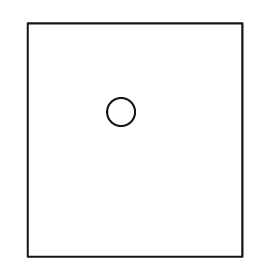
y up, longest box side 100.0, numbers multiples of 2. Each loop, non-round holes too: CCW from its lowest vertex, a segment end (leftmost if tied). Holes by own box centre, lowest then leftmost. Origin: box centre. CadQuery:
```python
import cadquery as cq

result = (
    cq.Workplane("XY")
    .moveTo(-46.0, -50.0)
    .lineTo(46.0, -50.0)
    .lineTo(46.0, 50.0)
    .lineTo(-46.0, 50.0)
    .close()
    .moveTo(-6.0, 12.0)
    .circle(6.0)
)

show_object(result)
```